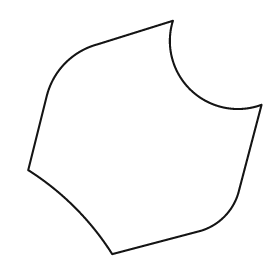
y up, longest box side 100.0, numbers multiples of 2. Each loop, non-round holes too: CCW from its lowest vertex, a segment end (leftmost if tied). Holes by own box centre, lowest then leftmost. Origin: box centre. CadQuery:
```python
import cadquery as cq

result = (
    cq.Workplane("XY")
    .moveTo(-14.0, -50.0)
    .lineTo(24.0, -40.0)
    .threePointArc((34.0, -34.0), (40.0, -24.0))
    .lineTo(50.0, 14.0)
    .threePointArc((20.0, 20.0), (12.0, 50.0))
    .lineTo(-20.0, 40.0)
    .threePointArc((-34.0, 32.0), (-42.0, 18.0))
    .lineTo(-50.0, -14.0)
    .threePointArc((-30.0, -30.0), (-14.0, -50.0))
    .close()
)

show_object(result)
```